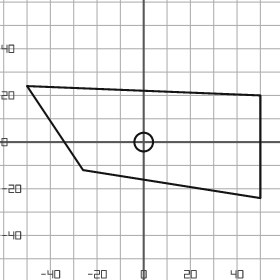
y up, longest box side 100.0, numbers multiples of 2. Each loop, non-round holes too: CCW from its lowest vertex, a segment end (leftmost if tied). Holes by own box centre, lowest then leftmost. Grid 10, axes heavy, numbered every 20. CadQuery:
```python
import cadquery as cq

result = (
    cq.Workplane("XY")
    .moveTo(50.0, -24.0)
    .lineTo(50.0, 20.0)
    .lineTo(-50.0, 24.0)
    .lineTo(-26.0, -12.0)
    .close()
    .moveTo(0.0, 0.0)
    .circle(4.0)
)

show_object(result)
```